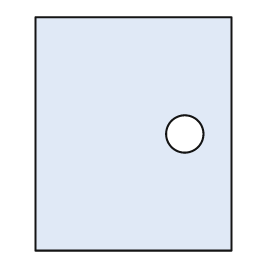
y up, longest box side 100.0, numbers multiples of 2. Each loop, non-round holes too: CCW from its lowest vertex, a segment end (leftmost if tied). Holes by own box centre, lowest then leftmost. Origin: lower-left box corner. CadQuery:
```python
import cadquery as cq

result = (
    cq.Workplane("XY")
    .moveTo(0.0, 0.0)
    .lineTo(84.0, 0.0)
    .lineTo(84.0, 100.0)
    .lineTo(0.0, 100.0)
    .close()
    .moveTo(64.0, 50.0)
    .circle(8.0)
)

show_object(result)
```